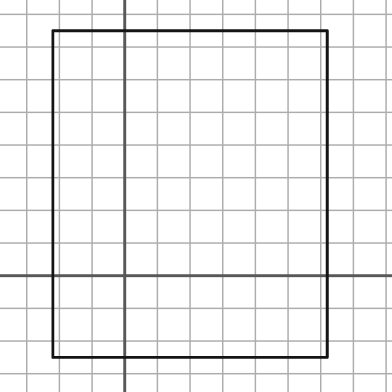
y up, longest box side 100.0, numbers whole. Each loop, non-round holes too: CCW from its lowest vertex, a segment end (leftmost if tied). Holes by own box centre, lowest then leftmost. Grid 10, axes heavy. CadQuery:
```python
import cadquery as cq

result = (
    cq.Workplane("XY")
    .moveTo(-22.0, -25.0)
    .lineTo(62.0, -25.0)
    .lineTo(62.0, 75.0)
    .lineTo(-22.0, 75.0)
    .close()
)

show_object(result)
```